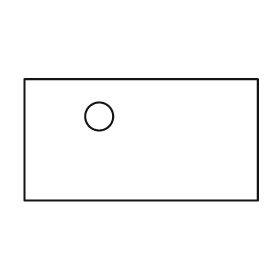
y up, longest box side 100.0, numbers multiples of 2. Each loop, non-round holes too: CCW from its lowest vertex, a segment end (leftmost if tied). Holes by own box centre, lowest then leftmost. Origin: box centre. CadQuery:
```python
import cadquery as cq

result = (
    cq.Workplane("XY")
    .moveTo(-50.0, -26.0)
    .lineTo(50.0, -26.0)
    .lineTo(50.0, 26.0)
    .lineTo(-50.0, 26.0)
    .close()
    .moveTo(-18.0, 10.0)
    .circle(6.0)
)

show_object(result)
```